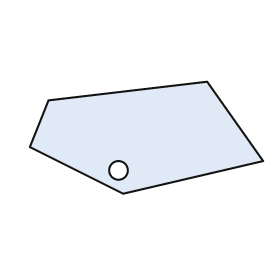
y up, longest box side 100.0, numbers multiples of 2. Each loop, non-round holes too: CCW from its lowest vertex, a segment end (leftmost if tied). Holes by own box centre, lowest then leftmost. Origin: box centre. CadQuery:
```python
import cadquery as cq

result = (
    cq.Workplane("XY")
    .moveTo(-10.0, -24.0)
    .lineTo(50.0, -10.0)
    .lineTo(26.0, 24.0)
    .lineTo(-42.0, 16.0)
    .lineTo(-50.0, -4.0)
    .close()
    .moveTo(-12.0, -14.0)
    .circle(4.0)
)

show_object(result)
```